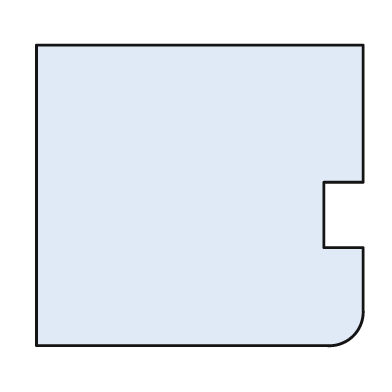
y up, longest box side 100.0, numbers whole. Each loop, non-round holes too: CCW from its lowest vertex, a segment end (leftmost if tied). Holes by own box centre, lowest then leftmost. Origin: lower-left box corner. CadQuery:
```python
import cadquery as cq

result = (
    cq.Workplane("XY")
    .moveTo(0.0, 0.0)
    .lineTo(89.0, 0.0)
    .threePointArc((97.0, 3.0), (100.0, 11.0))
    .lineTo(100.0, 30.0)
    .lineTo(88.0, 30.0)
    .lineTo(88.0, 50.0)
    .lineTo(100.0, 50.0)
    .lineTo(100.0, 92.0)
    .lineTo(0.0, 92.0)
    .close()
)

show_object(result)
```